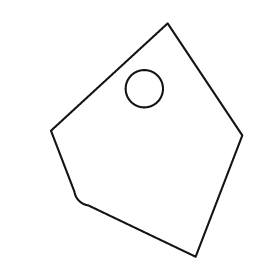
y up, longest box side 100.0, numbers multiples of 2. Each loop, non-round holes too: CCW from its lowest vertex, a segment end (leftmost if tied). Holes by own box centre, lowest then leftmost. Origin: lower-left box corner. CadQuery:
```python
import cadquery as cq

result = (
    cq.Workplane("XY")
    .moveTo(62.0, 0.0)
    .lineTo(82.0, 52.0)
    .lineTo(50.0, 100.0)
    .lineTo(0.0, 54.0)
    .lineTo(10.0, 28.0)
    .threePointArc((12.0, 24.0), (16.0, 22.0))
    .close()
    .moveTo(40.0, 72.0)
    .circle(8.0)
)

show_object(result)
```